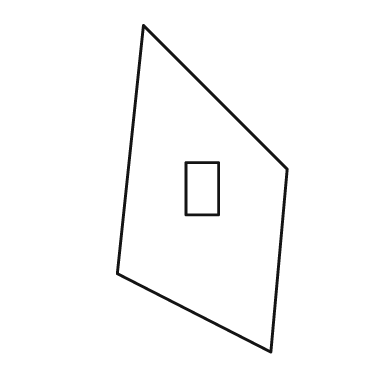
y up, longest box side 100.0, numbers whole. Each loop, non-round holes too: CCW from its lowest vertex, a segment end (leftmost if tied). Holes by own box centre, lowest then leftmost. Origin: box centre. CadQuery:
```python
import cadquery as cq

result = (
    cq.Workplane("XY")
    .moveTo(21.0, -50.0)
    .lineTo(26.0, 6.0)
    .lineTo(-18.0, 50.0)
    .lineTo(-26.0, -26.0)
    .close()
    .moveTo(-5.0, -8.0)
    .lineTo(5.0, -8.0)
    .lineTo(5.0, 8.0)
    .lineTo(-5.0, 8.0)
    .close()
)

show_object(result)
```